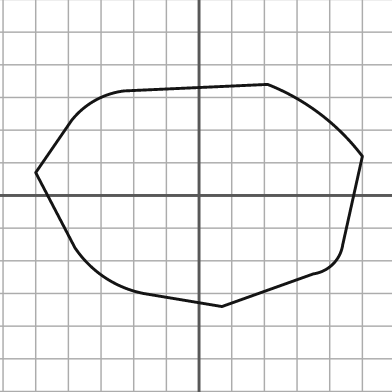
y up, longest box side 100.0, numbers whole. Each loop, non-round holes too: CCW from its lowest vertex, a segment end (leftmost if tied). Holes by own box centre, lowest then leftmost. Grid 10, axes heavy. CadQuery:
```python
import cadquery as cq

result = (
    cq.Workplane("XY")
    .moveTo(7.0, -34.0)
    .lineTo(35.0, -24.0)
    .threePointArc((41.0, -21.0), (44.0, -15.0))
    .lineTo(50.0, 12.0)
    .threePointArc((37.0, 25.0), (21.0, 34.0))
    .lineTo(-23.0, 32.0)
    .threePointArc((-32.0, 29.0), (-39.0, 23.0))
    .lineTo(-50.0, 7.0)
    .lineTo(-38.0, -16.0)
    .threePointArc((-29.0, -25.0), (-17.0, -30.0))
    .close()
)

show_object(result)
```